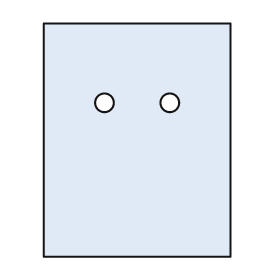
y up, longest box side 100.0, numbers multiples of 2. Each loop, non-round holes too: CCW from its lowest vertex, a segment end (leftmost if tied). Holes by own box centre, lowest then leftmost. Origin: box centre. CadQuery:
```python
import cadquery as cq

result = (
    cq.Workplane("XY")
    .moveTo(-40.0, -50.0)
    .lineTo(40.0, -50.0)
    .lineTo(40.0, 50.0)
    .lineTo(-40.0, 50.0)
    .close()
    .moveTo(-14.0, 16.0)
    .circle(4.0)
    .moveTo(14.0, 16.0)
    .circle(4.0)
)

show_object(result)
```